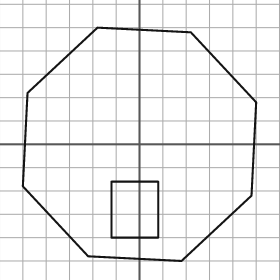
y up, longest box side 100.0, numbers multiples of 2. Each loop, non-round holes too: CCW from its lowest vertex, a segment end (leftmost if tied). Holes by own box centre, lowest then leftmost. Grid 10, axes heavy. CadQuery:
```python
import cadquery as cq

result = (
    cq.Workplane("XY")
    .moveTo(18.0, -50.0)
    .lineTo(48.0, -22.0)
    .lineTo(50.0, 18.0)
    .lineTo(22.0, 48.0)
    .lineTo(-18.0, 50.0)
    .lineTo(-48.0, 22.0)
    .lineTo(-50.0, -18.0)
    .lineTo(-22.0, -48.0)
    .close()
    .moveTo(-12.0, -40.0)
    .lineTo(8.0, -40.0)
    .lineTo(8.0, -16.0)
    .lineTo(-12.0, -16.0)
    .close()
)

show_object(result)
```